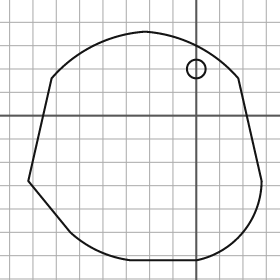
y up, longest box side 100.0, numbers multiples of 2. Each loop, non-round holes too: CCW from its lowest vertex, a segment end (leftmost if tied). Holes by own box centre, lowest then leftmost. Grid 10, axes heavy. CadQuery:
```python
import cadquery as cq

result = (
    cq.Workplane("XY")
    .moveTo(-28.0, -62.0)
    .lineTo(0.0, -62.0)
    .threePointArc((20.0, -50.0), (28.0, -28.0))
    .lineTo(18.0, 16.0)
    .threePointArc((0.0, 30.0), (-22.0, 36.0))
    .threePointArc((-44.0, 30.0), (-62.0, 16.0))
    .lineTo(-72.0, -28.0)
    .lineTo(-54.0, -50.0)
    .threePointArc((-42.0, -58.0), (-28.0, -62.0))
    .close()
    .moveTo(0.0, 20.0)
    .circle(4.0)
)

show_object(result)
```